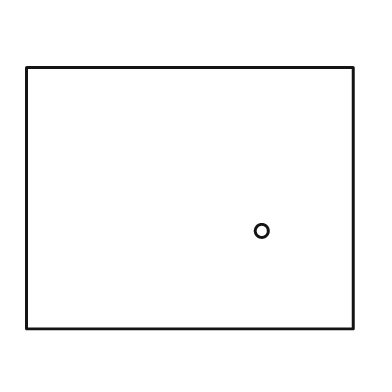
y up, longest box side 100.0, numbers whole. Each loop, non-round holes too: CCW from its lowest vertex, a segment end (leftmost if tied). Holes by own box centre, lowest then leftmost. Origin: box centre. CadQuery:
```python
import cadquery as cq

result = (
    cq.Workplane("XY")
    .moveTo(-50.0, -40.0)
    .lineTo(50.0, -40.0)
    .lineTo(50.0, 40.0)
    .lineTo(-50.0, 40.0)
    .close()
    .moveTo(22.0, -10.0)
    .circle(2.0)
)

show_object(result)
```